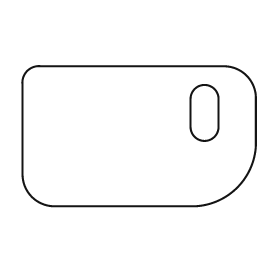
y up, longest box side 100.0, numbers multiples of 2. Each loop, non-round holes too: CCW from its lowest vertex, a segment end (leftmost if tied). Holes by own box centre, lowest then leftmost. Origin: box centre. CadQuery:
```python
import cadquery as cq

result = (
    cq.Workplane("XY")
    .moveTo(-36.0, -30.0)
    .lineTo(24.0, -30.0)
    .threePointArc((42.0, -22.0), (50.0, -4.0))
    .lineTo(50.0, 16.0)
    .threePointArc((46.0, 26.0), (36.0, 30.0))
    .lineTo(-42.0, 30.0)
    .threePointArc((-48.0, 28.0), (-50.0, 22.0))
    .lineTo(-50.0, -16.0)
    .threePointArc((-46.0, -26.0), (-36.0, -30.0))
    .close()
    .moveTo(22.0, 4.0)
    .threePointArc((28.0, -2.0), (34.0, 4.0))
    .lineTo(34.0, 16.0)
    .threePointArc((28.0, 22.0), (22.0, 16.0))
    .close()
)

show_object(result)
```